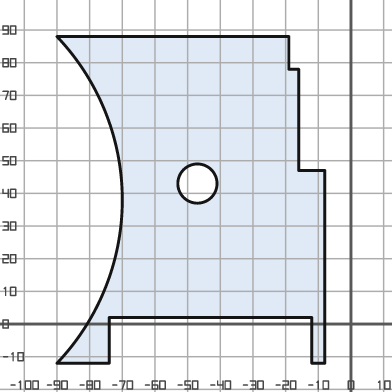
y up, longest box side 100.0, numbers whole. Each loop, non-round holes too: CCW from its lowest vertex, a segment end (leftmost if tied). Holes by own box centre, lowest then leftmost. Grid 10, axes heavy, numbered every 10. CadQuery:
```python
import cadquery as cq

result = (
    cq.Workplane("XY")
    .moveTo(-90.0, -12.0)
    .lineTo(-74.0, -12.0)
    .lineTo(-74.0, 2.0)
    .lineTo(-12.0, 2.0)
    .lineTo(-12.0, -12.0)
    .lineTo(-8.0, -12.0)
    .lineTo(-8.0, 47.0)
    .lineTo(-16.0, 47.0)
    .lineTo(-16.0, 78.0)
    .lineTo(-19.0, 78.0)
    .lineTo(-19.0, 88.0)
    .lineTo(-90.0, 88.0)
    .threePointArc((-70.0, 38.0), (-90.0, -12.0))
    .close()
    .moveTo(-47.0, 43.0)
    .circle(6.0)
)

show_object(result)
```